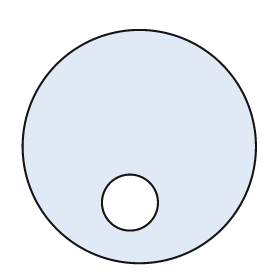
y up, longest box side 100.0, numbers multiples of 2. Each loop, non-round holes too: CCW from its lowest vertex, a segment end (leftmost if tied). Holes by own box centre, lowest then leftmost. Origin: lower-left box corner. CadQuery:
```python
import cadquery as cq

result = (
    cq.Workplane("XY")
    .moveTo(50.0, 50.0)
    .circle(50.0)
    .moveTo(46.0, 26.0)
    .circle(12.0)
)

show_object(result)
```